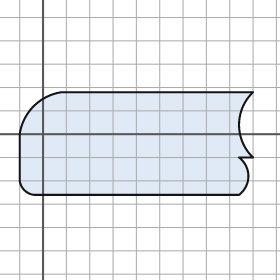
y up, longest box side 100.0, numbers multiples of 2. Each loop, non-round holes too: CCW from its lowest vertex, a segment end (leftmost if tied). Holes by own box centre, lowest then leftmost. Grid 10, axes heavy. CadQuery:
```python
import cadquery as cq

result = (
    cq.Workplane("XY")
    .moveTo(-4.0, -26.0)
    .lineTo(84.0, -26.0)
    .threePointArc((88.0, -18.0), (84.0, -10.0))
    .lineTo(90.0, -10.0)
    .threePointArc((84.0, 4.0), (90.0, 18.0))
    .lineTo(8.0, 18.0)
    .threePointArc((-4.0, 12.0), (-10.0, 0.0))
    .lineTo(-10.0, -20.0)
    .threePointArc((-8.0, -24.0), (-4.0, -26.0))
    .close()
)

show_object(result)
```